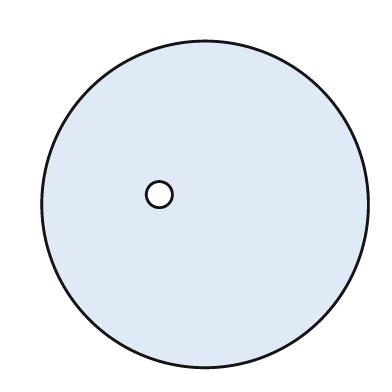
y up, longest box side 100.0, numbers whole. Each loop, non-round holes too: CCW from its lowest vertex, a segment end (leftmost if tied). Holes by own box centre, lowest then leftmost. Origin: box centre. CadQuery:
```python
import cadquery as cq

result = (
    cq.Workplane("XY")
    .moveTo(0.0, 0.0)
    .circle(50.0)
    .moveTo(-14.0, 3.0)
    .circle(4.0)
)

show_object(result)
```